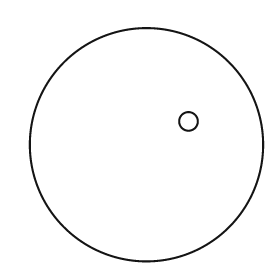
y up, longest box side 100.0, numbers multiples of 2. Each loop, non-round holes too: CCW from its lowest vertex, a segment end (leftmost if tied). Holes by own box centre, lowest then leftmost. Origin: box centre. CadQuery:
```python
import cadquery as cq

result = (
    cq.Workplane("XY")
    .moveTo(0.0, 0.0)
    .circle(50.0)
    .moveTo(18.0, 10.0)
    .circle(4.0)
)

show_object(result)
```